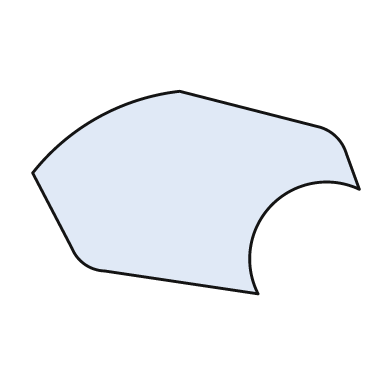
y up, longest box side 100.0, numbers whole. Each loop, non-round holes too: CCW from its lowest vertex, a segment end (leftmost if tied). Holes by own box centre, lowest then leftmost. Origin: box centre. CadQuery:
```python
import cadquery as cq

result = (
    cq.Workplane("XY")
    .moveTo(19.0, -31.0)
    .threePointArc((23.0, -4.0), (50.0, 1.0))
    .lineTo(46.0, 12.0)
    .threePointArc((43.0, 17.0), (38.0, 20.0))
    .lineTo(-5.0, 31.0)
    .threePointArc((-30.0, 23.0), (-50.0, 6.0))
    .lineTo(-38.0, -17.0)
    .threePointArc((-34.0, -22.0), (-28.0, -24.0))
    .close()
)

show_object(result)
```